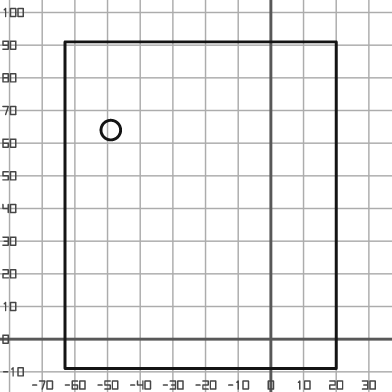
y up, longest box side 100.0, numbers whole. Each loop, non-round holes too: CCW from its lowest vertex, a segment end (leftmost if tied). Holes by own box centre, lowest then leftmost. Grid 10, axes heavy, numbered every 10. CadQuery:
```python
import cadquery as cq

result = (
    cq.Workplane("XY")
    .moveTo(-63.0, -9.0)
    .lineTo(20.0, -9.0)
    .lineTo(20.0, 91.0)
    .lineTo(-63.0, 91.0)
    .close()
    .moveTo(-49.0, 64.0)
    .circle(3.0)
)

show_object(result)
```